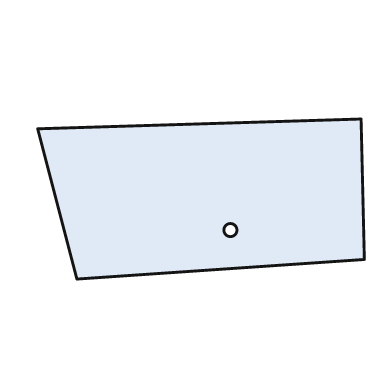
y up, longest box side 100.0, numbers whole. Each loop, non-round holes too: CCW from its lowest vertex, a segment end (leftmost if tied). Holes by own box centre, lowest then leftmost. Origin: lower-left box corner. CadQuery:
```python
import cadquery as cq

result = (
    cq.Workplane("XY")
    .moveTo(12.0, 0.0)
    .lineTo(100.0, 6.0)
    .lineTo(99.0, 49.0)
    .lineTo(0.0, 46.0)
    .close()
    .moveTo(59.0, 15.0)
    .circle(2.0)
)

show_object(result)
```